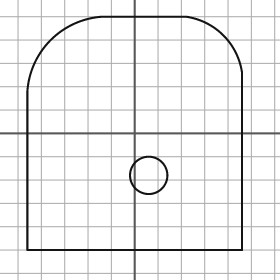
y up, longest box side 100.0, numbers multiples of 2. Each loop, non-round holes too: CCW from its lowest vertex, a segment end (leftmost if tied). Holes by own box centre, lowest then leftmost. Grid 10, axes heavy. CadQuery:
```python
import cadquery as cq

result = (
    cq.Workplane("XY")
    .moveTo(-46.0, -50.0)
    .lineTo(46.0, -50.0)
    .lineTo(46.0, 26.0)
    .threePointArc((38.0, 42.0), (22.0, 50.0))
    .lineTo(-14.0, 50.0)
    .threePointArc((-36.0, 40.0), (-46.0, 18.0))
    .close()
    .moveTo(6.0, -18.0)
    .circle(8.0)
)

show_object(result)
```